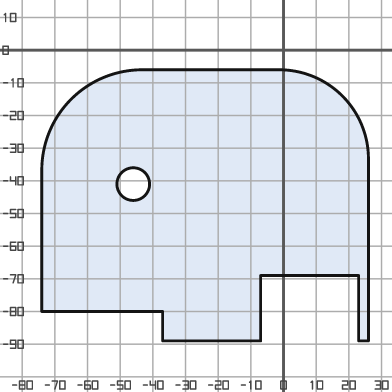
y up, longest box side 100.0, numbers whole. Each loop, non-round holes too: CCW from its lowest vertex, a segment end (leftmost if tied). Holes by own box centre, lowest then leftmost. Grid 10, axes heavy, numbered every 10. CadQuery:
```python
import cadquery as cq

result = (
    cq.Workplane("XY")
    .moveTo(-37.0, -89.0)
    .lineTo(-7.0, -89.0)
    .lineTo(-7.0, -69.0)
    .lineTo(23.0, -69.0)
    .lineTo(23.0, -89.0)
    .lineTo(26.0, -89.0)
    .lineTo(26.0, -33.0)
    .threePointArc((18.0, -14.0), (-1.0, -6.0))
    .lineTo(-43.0, -6.0)
    .threePointArc((-65.0, -15.0), (-74.0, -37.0))
    .lineTo(-74.0, -80.0)
    .lineTo(-37.0, -80.0)
    .close()
    .moveTo(-46.0, -41.0)
    .circle(5.0)
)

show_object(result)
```